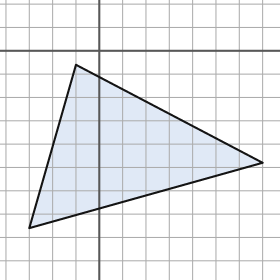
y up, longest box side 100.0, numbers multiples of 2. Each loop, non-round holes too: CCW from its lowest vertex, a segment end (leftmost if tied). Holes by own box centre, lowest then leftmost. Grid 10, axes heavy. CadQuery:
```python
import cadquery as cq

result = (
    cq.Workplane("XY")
    .moveTo(-30.0, -76.0)
    .lineTo(70.0, -48.0)
    .lineTo(-10.0, -6.0)
    .close()
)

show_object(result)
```